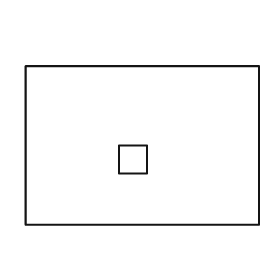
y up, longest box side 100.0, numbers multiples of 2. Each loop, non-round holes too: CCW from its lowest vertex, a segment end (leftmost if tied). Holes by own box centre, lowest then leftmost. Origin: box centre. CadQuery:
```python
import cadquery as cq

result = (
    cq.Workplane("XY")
    .moveTo(-50.0, -34.0)
    .lineTo(50.0, -34.0)
    .lineTo(50.0, 34.0)
    .lineTo(-50.0, 34.0)
    .close()
    .moveTo(-10.0, -12.0)
    .lineTo(2.0, -12.0)
    .lineTo(2.0, 0.0)
    .lineTo(-10.0, 0.0)
    .close()
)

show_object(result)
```